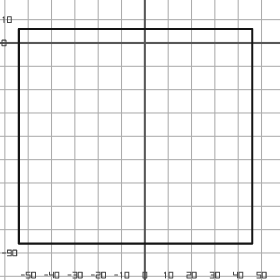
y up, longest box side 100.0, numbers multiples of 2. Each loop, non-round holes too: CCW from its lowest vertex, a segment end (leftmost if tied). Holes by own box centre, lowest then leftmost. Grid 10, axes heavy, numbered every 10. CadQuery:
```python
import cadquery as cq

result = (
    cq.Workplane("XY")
    .moveTo(-54.0, -86.0)
    .lineTo(46.0, -86.0)
    .lineTo(46.0, 6.0)
    .lineTo(-54.0, 6.0)
    .close()
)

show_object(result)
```